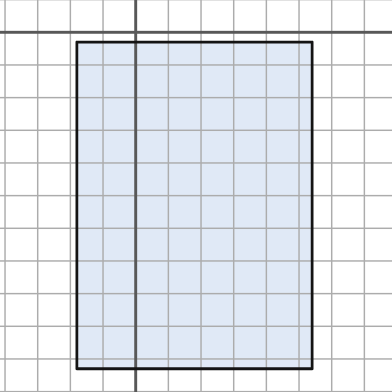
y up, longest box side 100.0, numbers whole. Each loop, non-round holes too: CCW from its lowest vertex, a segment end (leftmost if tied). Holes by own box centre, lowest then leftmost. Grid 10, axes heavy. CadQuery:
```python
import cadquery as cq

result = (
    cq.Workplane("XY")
    .moveTo(-18.0, -103.0)
    .lineTo(54.0, -103.0)
    .lineTo(54.0, -3.0)
    .lineTo(-18.0, -3.0)
    .close()
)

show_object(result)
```